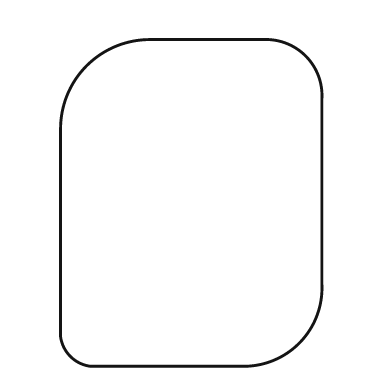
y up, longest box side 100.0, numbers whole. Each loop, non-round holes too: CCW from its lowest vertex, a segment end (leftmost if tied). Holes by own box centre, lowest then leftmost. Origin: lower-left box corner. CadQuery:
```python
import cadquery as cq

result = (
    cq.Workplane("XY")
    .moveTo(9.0, 0.0)
    .lineTo(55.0, 0.0)
    .threePointArc((73.0, 7.0), (80.0, 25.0))
    .lineTo(80.0, 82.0)
    .threePointArc((75.0, 95.0), (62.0, 100.0))
    .lineTo(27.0, 100.0)
    .threePointArc((8.0, 92.0), (0.0, 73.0))
    .lineTo(0.0, 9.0)
    .threePointArc((3.0, 3.0), (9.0, 0.0))
    .close()
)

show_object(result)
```